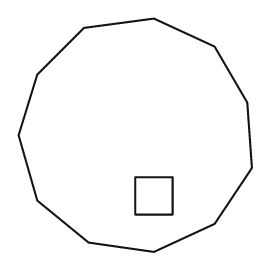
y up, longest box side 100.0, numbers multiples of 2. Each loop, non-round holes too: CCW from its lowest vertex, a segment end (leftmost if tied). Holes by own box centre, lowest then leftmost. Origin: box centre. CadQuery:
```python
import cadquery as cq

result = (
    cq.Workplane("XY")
    .moveTo(8.0, -50.0)
    .lineTo(34.0, -38.0)
    .lineTo(50.0, -14.0)
    .lineTo(48.0, 14.0)
    .lineTo(34.0, 38.0)
    .lineTo(8.0, 50.0)
    .lineTo(-22.0, 46.0)
    .lineTo(-42.0, 26.0)
    .lineTo(-50.0, 0.0)
    .lineTo(-42.0, -28.0)
    .lineTo(-20.0, -46.0)
    .close()
    .moveTo(0.0, -34.0)
    .lineTo(16.0, -34.0)
    .lineTo(16.0, -18.0)
    .lineTo(0.0, -18.0)
    .close()
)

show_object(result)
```